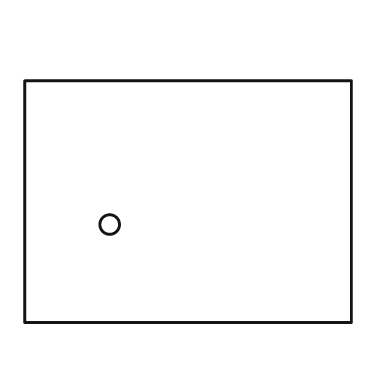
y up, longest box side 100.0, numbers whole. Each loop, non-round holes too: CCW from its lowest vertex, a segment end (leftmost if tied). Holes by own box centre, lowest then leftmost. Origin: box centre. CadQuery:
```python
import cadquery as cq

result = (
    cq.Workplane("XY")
    .moveTo(-50.0, -37.0)
    .lineTo(50.0, -37.0)
    .lineTo(50.0, 37.0)
    .lineTo(-50.0, 37.0)
    .close()
    .moveTo(-24.0, -7.0)
    .circle(3.0)
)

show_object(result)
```